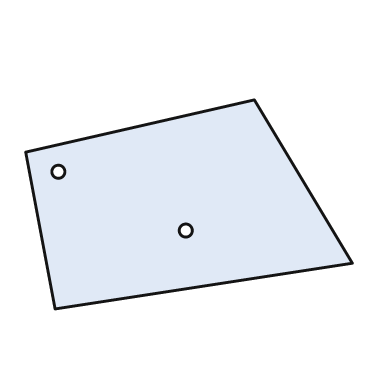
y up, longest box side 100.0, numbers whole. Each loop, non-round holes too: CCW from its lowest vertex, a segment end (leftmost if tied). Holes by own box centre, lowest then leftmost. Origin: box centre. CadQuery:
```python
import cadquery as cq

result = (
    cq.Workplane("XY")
    .moveTo(-41.0, -32.0)
    .lineTo(50.0, -18.0)
    .lineTo(20.0, 32.0)
    .lineTo(-50.0, 16.0)
    .close()
    .moveTo(-1.0, -8.0)
    .circle(2.0)
    .moveTo(-40.0, 10.0)
    .circle(2.0)
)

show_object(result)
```